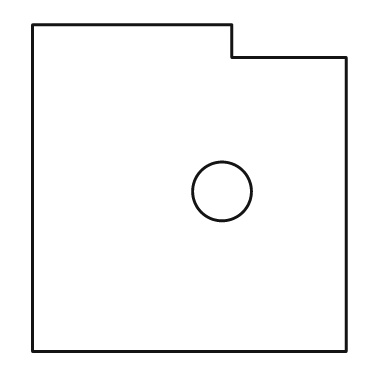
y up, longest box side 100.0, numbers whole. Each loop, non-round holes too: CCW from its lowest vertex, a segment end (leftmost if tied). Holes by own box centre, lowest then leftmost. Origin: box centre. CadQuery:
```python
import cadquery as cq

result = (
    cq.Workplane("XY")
    .moveTo(-48.0, -50.0)
    .lineTo(48.0, -50.0)
    .lineTo(48.0, 40.0)
    .lineTo(13.0, 40.0)
    .lineTo(13.0, 50.0)
    .lineTo(-48.0, 50.0)
    .close()
    .moveTo(10.0, -1.0)
    .circle(9.0)
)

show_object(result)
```